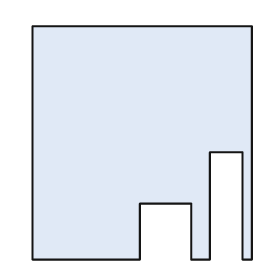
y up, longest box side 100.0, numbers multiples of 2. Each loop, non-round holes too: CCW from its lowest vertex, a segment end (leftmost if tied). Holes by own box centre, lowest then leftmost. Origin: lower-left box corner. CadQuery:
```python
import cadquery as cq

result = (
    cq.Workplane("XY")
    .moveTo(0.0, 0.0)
    .lineTo(46.0, 0.0)
    .lineTo(46.0, 24.0)
    .lineTo(68.0, 24.0)
    .lineTo(68.0, 0.0)
    .lineTo(76.0, 0.0)
    .lineTo(76.0, 46.0)
    .lineTo(90.0, 46.0)
    .lineTo(90.0, 0.0)
    .lineTo(94.0, 0.0)
    .lineTo(94.0, 100.0)
    .lineTo(0.0, 100.0)
    .close()
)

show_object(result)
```